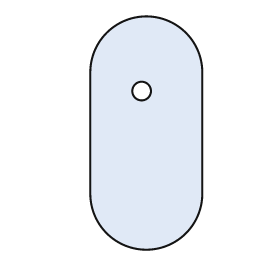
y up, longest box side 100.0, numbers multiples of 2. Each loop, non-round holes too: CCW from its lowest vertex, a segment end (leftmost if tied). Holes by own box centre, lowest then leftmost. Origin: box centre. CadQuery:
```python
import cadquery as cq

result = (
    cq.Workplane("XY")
    .moveTo(-24.0, -26.0)
    .threePointArc((0.0, -50.0), (24.0, -26.0))
    .lineTo(24.0, 26.0)
    .threePointArc((0.0, 50.0), (-24.0, 26.0))
    .close()
    .moveTo(-2.0, 18.0)
    .circle(4.0)
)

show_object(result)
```